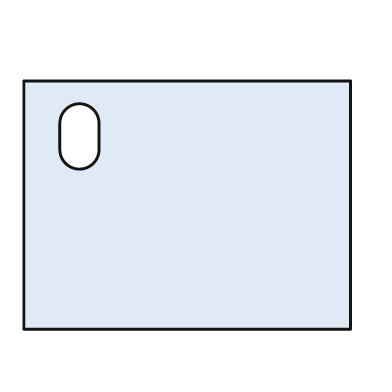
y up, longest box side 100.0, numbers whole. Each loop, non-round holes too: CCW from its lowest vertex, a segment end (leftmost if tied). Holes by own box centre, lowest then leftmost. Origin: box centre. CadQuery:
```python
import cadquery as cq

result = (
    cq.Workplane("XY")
    .moveTo(-50.0, -38.0)
    .lineTo(50.0, -38.0)
    .lineTo(50.0, 38.0)
    .lineTo(-50.0, 38.0)
    .close()
    .moveTo(-39.0, 17.0)
    .threePointArc((-33.0, 11.0), (-27.0, 17.0))
    .lineTo(-27.0, 25.0)
    .threePointArc((-33.0, 31.0), (-39.0, 25.0))
    .close()
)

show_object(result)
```